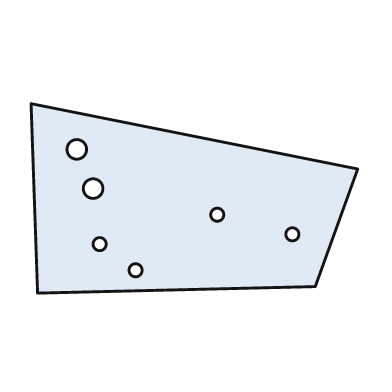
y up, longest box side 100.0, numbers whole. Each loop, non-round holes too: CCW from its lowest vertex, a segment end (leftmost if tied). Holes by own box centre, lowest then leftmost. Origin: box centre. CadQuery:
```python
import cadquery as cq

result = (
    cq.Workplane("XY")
    .moveTo(-48.0, -29.0)
    .lineTo(37.0, -27.0)
    .lineTo(50.0, 9.0)
    .lineTo(-50.0, 29.0)
    .close()
    .moveTo(-18.0, -22.0)
    .circle(2.0)
    .moveTo(-29.0, -14.0)
    .circle(2.0)
    .moveTo(30.0, -11.0)
    .circle(2.0)
    .moveTo(7.0, -5.0)
    .circle(2.0)
    .moveTo(-31.0, 3.0)
    .circle(3.0)
    .moveTo(-36.0, 15.0)
    .circle(3.0)
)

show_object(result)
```